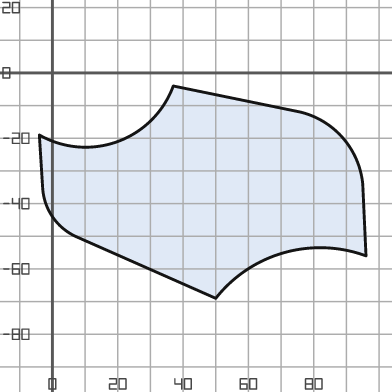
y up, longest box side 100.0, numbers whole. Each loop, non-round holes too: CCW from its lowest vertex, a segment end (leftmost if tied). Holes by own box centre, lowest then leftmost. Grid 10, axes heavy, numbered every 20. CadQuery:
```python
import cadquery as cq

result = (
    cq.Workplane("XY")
    .moveTo(50.0, -69.0)
    .threePointArc((71.0, -55.0), (96.0, -56.0))
    .lineTo(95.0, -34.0)
    .threePointArc((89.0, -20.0), (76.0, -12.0))
    .lineTo(37.0, -4.0)
    .threePointArc((20.0, -21.0), (-4.0, -19.0))
    .lineTo(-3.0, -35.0)
    .threePointArc((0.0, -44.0), (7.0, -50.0))
    .close()
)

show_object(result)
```